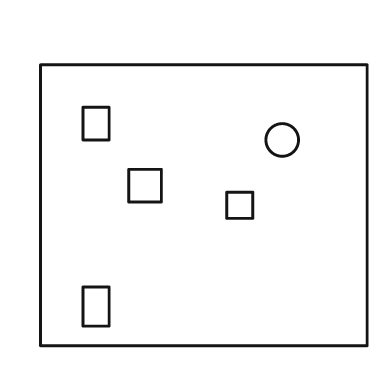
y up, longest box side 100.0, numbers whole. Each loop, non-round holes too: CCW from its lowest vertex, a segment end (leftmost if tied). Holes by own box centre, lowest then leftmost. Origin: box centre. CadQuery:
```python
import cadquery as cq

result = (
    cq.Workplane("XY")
    .moveTo(-50.0, -43.0)
    .lineTo(50.0, -43.0)
    .lineTo(50.0, 43.0)
    .lineTo(-50.0, 43.0)
    .close()
    .moveTo(-37.0, -37.0)
    .lineTo(-29.0, -37.0)
    .lineTo(-29.0, -25.0)
    .lineTo(-37.0, -25.0)
    .close()
    .moveTo(7.0, -4.0)
    .lineTo(15.0, -4.0)
    .lineTo(15.0, 4.0)
    .lineTo(7.0, 4.0)
    .close()
    .moveTo(-23.0, 1.0)
    .lineTo(-13.0, 1.0)
    .lineTo(-13.0, 11.0)
    .lineTo(-23.0, 11.0)
    .close()
    .moveTo(24.0, 20.0)
    .circle(5.0)
    .moveTo(-37.0, 20.0)
    .lineTo(-29.0, 20.0)
    .lineTo(-29.0, 30.0)
    .lineTo(-37.0, 30.0)
    .close()
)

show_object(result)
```